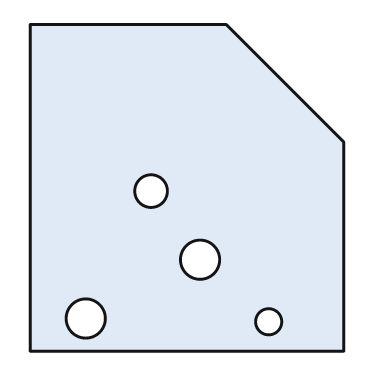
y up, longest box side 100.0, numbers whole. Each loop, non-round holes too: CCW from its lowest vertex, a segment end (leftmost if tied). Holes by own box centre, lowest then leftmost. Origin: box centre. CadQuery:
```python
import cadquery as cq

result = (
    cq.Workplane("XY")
    .moveTo(-48.0, -50.0)
    .lineTo(48.0, -50.0)
    .lineTo(48.0, 14.0)
    .lineTo(12.0, 50.0)
    .lineTo(-48.0, 50.0)
    .close()
    .moveTo(25.0, -41.0)
    .circle(4.0)
    .moveTo(-31.0, -40.0)
    .circle(6.0)
    .moveTo(4.0, -22.0)
    .circle(6.0)
    .moveTo(-11.0, -1.0)
    .circle(5.0)
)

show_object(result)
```